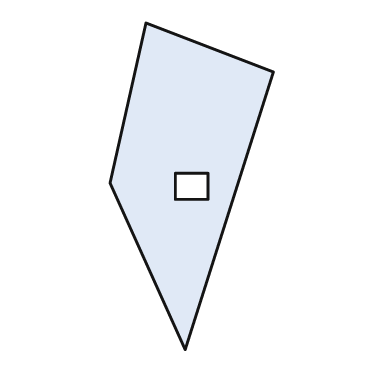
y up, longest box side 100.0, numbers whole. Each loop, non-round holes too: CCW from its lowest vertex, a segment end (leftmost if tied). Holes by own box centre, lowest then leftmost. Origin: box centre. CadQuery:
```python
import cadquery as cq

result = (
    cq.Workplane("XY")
    .moveTo(-2.0, -50.0)
    .lineTo(25.0, 35.0)
    .lineTo(-14.0, 50.0)
    .lineTo(-25.0, 1.0)
    .close()
    .moveTo(-5.0, -4.0)
    .lineTo(5.0, -4.0)
    .lineTo(5.0, 4.0)
    .lineTo(-5.0, 4.0)
    .close()
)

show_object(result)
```